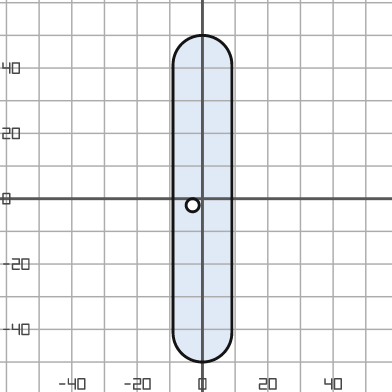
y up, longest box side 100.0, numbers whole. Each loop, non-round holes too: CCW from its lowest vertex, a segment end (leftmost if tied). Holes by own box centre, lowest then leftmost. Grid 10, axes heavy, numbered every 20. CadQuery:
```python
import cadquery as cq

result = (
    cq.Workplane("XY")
    .moveTo(-9.0, -41.0)
    .threePointArc((0.0, -50.0), (9.0, -41.0))
    .lineTo(9.0, 41.0)
    .threePointArc((0.0, 50.0), (-9.0, 41.0))
    .close()
    .moveTo(-3.0, -2.0)
    .circle(2.0)
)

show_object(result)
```